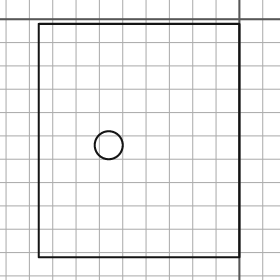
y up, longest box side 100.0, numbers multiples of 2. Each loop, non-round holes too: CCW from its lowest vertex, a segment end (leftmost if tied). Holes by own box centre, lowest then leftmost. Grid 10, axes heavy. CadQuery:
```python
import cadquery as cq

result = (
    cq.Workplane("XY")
    .moveTo(-86.0, -102.0)
    .lineTo(0.0, -102.0)
    .lineTo(0.0, -2.0)
    .lineTo(-86.0, -2.0)
    .close()
    .moveTo(-56.0, -54.0)
    .circle(6.0)
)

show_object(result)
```